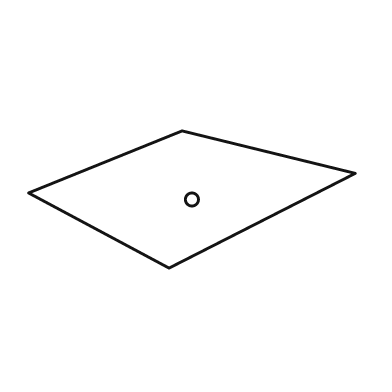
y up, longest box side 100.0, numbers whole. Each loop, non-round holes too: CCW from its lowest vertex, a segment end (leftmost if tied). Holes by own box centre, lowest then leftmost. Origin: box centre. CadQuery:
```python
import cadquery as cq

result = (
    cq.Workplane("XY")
    .moveTo(-7.0, -21.0)
    .lineTo(50.0, 8.0)
    .lineTo(-3.0, 21.0)
    .lineTo(-50.0, 2.0)
    .close()
    .moveTo(0.0, 0.0)
    .circle(2.0)
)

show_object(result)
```